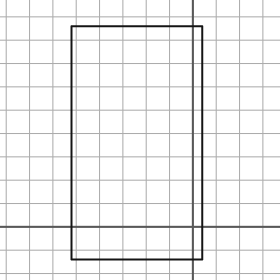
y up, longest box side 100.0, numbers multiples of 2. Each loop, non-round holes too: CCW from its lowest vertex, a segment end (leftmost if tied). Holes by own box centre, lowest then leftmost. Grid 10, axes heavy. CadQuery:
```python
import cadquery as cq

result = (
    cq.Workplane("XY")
    .moveTo(-52.0, -14.0)
    .lineTo(4.0, -14.0)
    .lineTo(4.0, 86.0)
    .lineTo(-52.0, 86.0)
    .close()
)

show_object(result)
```